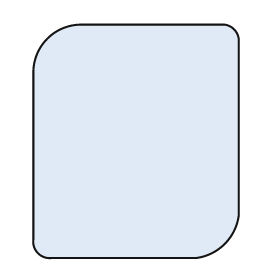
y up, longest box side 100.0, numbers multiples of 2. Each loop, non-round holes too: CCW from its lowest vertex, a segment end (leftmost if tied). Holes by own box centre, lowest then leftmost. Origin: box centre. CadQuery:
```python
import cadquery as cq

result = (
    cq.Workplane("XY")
    .moveTo(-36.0, -50.0)
    .lineTo(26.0, -50.0)
    .threePointArc((38.0, -44.0), (44.0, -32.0))
    .lineTo(44.0, 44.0)
    .threePointArc((42.0, 48.0), (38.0, 50.0))
    .lineTo(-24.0, 50.0)
    .threePointArc((-38.0, 44.0), (-44.0, 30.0))
    .lineTo(-44.0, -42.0)
    .threePointArc((-42.0, -48.0), (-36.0, -50.0))
    .close()
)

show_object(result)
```